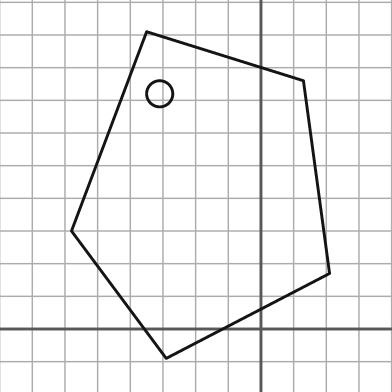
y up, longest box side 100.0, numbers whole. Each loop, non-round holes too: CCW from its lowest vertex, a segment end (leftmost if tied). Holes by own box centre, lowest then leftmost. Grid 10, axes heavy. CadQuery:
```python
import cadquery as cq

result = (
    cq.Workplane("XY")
    .moveTo(-29.0, -9.0)
    .lineTo(21.0, 17.0)
    .lineTo(13.0, 76.0)
    .lineTo(-35.0, 91.0)
    .lineTo(-58.0, 30.0)
    .close()
    .moveTo(-31.0, 72.0)
    .circle(4.0)
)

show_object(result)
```